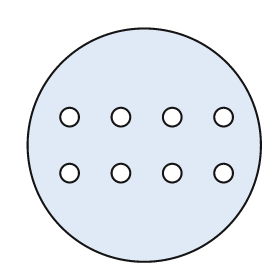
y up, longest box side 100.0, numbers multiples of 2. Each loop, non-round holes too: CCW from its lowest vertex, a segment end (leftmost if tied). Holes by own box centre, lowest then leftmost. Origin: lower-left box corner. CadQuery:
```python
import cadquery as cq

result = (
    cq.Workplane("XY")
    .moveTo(50.0, 50.0)
    .circle(50.0)
    .moveTo(18.0, 38.0)
    .circle(4.0)
    .moveTo(40.0, 38.0)
    .circle(4.0)
    .moveTo(62.0, 38.0)
    .circle(4.0)
    .moveTo(84.0, 38.0)
    .circle(4.0)
    .moveTo(18.0, 62.0)
    .circle(4.0)
    .moveTo(40.0, 62.0)
    .circle(4.0)
    .moveTo(62.0, 62.0)
    .circle(4.0)
    .moveTo(84.0, 62.0)
    .circle(4.0)
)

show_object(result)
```